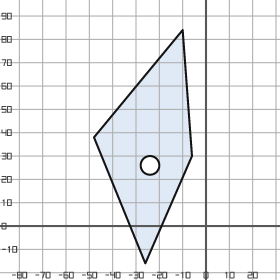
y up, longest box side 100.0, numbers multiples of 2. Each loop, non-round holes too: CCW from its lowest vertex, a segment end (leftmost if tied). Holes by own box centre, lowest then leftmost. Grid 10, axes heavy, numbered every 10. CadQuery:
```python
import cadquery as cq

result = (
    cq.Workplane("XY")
    .moveTo(-26.0, -16.0)
    .lineTo(-6.0, 30.0)
    .lineTo(-10.0, 84.0)
    .lineTo(-48.0, 38.0)
    .close()
    .moveTo(-24.0, 26.0)
    .circle(4.0)
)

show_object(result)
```